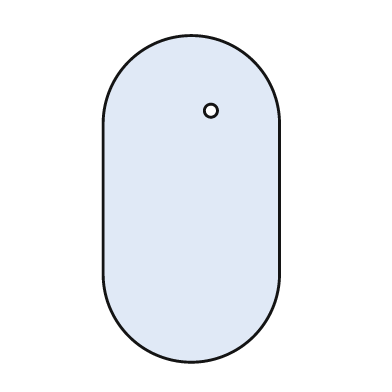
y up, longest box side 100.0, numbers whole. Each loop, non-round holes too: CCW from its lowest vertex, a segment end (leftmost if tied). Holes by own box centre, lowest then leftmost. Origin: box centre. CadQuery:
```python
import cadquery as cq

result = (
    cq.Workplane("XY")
    .moveTo(-27.0, -23.0)
    .threePointArc((0.0, -50.0), (27.0, -23.0))
    .lineTo(27.0, 23.0)
    .threePointArc((0.0, 50.0), (-27.0, 23.0))
    .close()
    .moveTo(6.0, 27.0)
    .circle(2.0)
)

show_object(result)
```